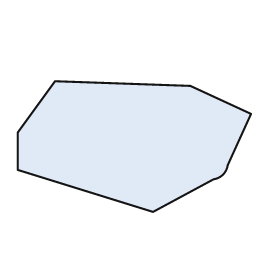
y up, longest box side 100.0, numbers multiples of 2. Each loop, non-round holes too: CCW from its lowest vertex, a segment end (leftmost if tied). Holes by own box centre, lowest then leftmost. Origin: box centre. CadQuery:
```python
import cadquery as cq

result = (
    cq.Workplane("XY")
    .moveTo(8.0, -28.0)
    .lineTo(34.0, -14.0)
    .threePointArc((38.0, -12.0), (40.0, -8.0))
    .lineTo(50.0, 14.0)
    .lineTo(24.0, 26.0)
    .lineTo(-34.0, 28.0)
    .lineTo(-50.0, 6.0)
    .lineTo(-50.0, -10.0)
    .close()
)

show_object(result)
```